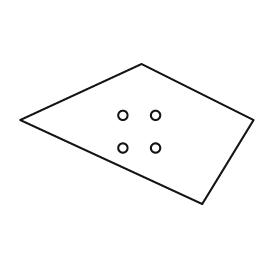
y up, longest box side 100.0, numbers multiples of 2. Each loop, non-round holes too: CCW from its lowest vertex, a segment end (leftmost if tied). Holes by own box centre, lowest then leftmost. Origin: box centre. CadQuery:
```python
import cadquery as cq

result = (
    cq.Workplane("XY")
    .moveTo(28.0, -30.0)
    .lineTo(50.0, 6.0)
    .lineTo(2.0, 30.0)
    .lineTo(-50.0, 6.0)
    .close()
    .moveTo(-6.0, -6.0)
    .circle(2.0)
    .moveTo(8.0, -6.0)
    .circle(2.0)
    .moveTo(-6.0, 8.0)
    .circle(2.0)
    .moveTo(8.0, 8.0)
    .circle(2.0)
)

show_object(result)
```